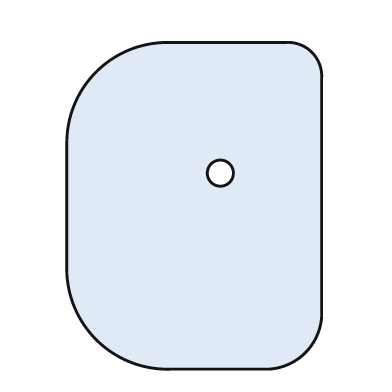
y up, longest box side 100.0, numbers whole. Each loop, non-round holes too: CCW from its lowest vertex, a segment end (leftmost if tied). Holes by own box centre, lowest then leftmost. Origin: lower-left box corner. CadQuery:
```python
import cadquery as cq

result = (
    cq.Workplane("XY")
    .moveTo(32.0, 0.0)
    .lineTo(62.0, 0.0)
    .threePointArc((73.0, 5.0), (78.0, 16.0))
    .lineTo(78.0, 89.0)
    .threePointArc((75.0, 97.0), (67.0, 100.0))
    .lineTo(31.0, 100.0)
    .threePointArc((9.0, 91.0), (0.0, 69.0))
    .lineTo(0.0, 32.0)
    .threePointArc((9.0, 9.0), (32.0, 0.0))
    .close()
    .moveTo(47.0, 60.0)
    .circle(4.0)
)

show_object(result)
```